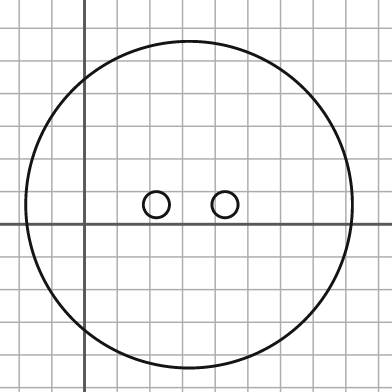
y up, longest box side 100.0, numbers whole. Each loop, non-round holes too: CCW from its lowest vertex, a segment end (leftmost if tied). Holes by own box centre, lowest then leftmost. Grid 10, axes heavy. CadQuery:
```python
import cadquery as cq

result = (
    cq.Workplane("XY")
    .moveTo(32.0, 6.0)
    .circle(50.0)
    .moveTo(22.0, 6.0)
    .circle(4.0)
    .moveTo(43.0, 6.0)
    .circle(4.0)
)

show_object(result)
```